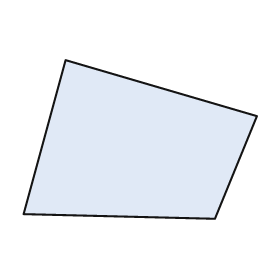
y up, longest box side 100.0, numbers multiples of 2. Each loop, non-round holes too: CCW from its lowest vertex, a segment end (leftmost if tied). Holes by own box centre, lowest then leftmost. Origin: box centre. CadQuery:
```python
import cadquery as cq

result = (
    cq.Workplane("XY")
    .moveTo(32.0, -34.0)
    .lineTo(50.0, 10.0)
    .lineTo(-32.0, 34.0)
    .lineTo(-50.0, -32.0)
    .close()
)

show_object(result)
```